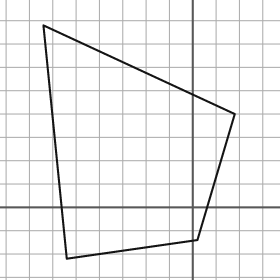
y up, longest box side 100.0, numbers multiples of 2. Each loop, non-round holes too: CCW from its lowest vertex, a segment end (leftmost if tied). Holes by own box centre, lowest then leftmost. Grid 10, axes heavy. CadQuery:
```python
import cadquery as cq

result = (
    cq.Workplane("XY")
    .moveTo(-54.0, -22.0)
    .lineTo(2.0, -14.0)
    .lineTo(18.0, 40.0)
    .lineTo(-64.0, 78.0)
    .close()
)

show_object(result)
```